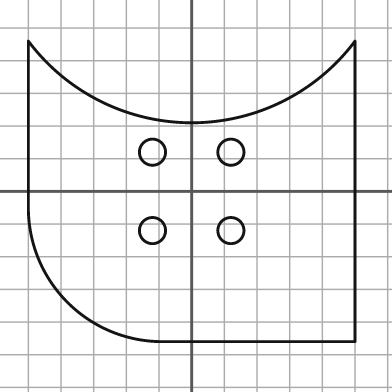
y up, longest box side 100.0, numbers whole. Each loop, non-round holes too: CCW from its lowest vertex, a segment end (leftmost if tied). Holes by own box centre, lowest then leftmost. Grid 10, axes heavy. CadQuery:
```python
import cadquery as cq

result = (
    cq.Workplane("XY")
    .moveTo(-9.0, -46.0)
    .lineTo(50.0, -46.0)
    .lineTo(50.0, 46.0)
    .threePointArc((0.0, 21.0), (-50.0, 46.0))
    .lineTo(-50.0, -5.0)
    .threePointArc((-38.0, -34.0), (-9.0, -46.0))
    .close()
    .moveTo(-12.0, -12.0)
    .circle(4.0)
    .moveTo(12.0, -12.0)
    .circle(4.0)
    .moveTo(-12.0, 12.0)
    .circle(4.0)
    .moveTo(12.0, 12.0)
    .circle(4.0)
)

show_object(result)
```